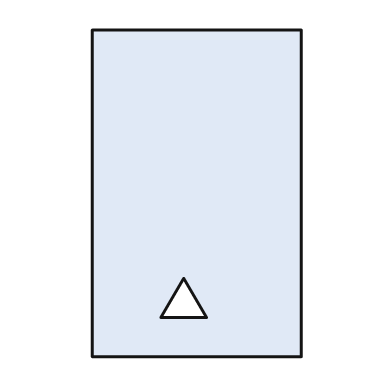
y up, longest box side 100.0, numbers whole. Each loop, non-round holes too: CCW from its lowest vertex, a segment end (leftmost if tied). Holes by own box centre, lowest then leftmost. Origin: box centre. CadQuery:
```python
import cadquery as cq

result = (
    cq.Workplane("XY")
    .moveTo(-32.0, -50.0)
    .lineTo(32.0, -50.0)
    .lineTo(32.0, 50.0)
    .lineTo(-32.0, 50.0)
    .close()
    .moveTo(-11.0, -38.0)
    .lineTo(3.0, -38.0)
    .lineTo(-4.0, -26.0)
    .close()
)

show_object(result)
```